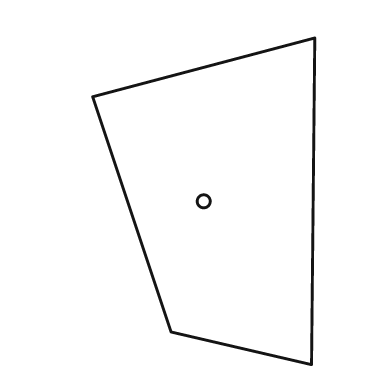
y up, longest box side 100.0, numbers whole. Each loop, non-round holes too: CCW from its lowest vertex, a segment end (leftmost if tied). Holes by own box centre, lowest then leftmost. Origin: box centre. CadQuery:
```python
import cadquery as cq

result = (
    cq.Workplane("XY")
    .moveTo(33.0, -50.0)
    .lineTo(34.0, 50.0)
    .lineTo(-34.0, 32.0)
    .lineTo(-10.0, -40.0)
    .close()
    .moveTo(0.0, 0.0)
    .circle(2.0)
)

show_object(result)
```